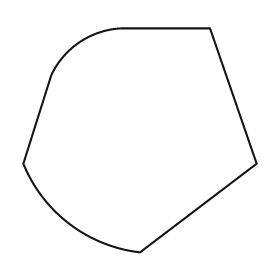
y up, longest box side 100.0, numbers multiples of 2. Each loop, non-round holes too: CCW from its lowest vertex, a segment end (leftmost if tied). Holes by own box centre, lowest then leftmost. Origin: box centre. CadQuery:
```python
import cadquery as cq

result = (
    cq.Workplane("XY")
    .moveTo(0.0, -48.0)
    .lineTo(50.0, -10.0)
    .lineTo(30.0, 48.0)
    .lineTo(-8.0, 48.0)
    .threePointArc((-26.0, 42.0), (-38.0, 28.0))
    .lineTo(-50.0, -10.0)
    .threePointArc((-30.0, -36.0), (0.0, -48.0))
    .close()
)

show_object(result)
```